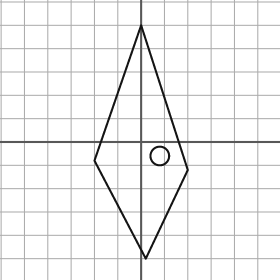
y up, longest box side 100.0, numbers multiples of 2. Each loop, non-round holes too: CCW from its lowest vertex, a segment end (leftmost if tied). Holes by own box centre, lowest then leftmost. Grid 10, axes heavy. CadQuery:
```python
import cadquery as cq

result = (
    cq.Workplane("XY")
    .moveTo(2.0, -50.0)
    .lineTo(20.0, -12.0)
    .lineTo(0.0, 50.0)
    .lineTo(-20.0, -8.0)
    .close()
    .moveTo(8.0, -6.0)
    .circle(4.0)
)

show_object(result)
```